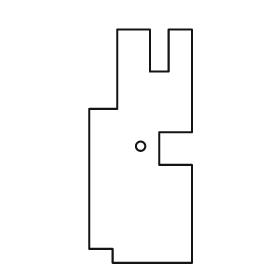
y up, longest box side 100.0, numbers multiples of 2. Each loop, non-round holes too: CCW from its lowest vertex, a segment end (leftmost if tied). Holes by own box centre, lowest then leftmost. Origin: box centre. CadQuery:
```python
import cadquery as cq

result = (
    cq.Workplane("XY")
    .moveTo(-12.0, -50.0)
    .lineTo(22.0, -50.0)
    .lineTo(22.0, -8.0)
    .lineTo(8.0, -8.0)
    .lineTo(8.0, 6.0)
    .lineTo(22.0, 6.0)
    .lineTo(22.0, 50.0)
    .lineTo(12.0, 50.0)
    .lineTo(12.0, 32.0)
    .lineTo(4.0, 32.0)
    .lineTo(4.0, 50.0)
    .lineTo(-10.0, 50.0)
    .lineTo(-10.0, 16.0)
    .lineTo(-22.0, 16.0)
    .lineTo(-22.0, -44.0)
    .lineTo(-12.0, -44.0)
    .close()
    .moveTo(0.0, 0.0)
    .circle(2.0)
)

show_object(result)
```